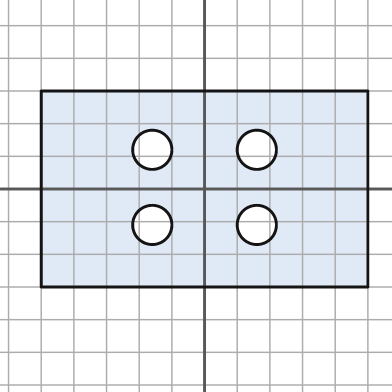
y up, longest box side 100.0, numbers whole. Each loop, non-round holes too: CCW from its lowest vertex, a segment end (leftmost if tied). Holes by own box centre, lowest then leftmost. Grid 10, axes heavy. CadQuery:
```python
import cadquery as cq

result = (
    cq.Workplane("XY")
    .moveTo(-50.0, -30.0)
    .lineTo(50.0, -30.0)
    .lineTo(50.0, 30.0)
    .lineTo(-50.0, 30.0)
    .close()
    .moveTo(-16.0, -11.0)
    .circle(6.0)
    .moveTo(16.0, -11.0)
    .circle(6.0)
    .moveTo(-16.0, 12.0)
    .circle(6.0)
    .moveTo(16.0, 12.0)
    .circle(6.0)
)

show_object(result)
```